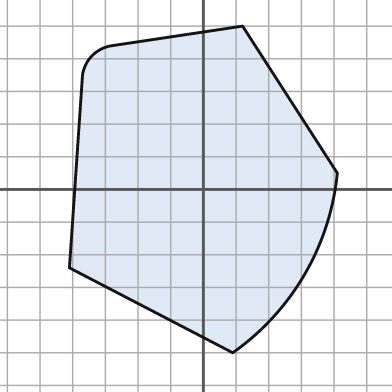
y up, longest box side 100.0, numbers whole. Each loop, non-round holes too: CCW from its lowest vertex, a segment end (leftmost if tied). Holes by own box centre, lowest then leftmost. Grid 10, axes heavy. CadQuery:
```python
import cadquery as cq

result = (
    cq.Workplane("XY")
    .moveTo(9.0, -50.0)
    .threePointArc((31.0, -26.0), (41.0, 5.0))
    .lineTo(12.0, 50.0)
    .lineTo(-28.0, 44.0)
    .threePointArc((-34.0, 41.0), (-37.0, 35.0))
    .lineTo(-41.0, -24.0)
    .close()
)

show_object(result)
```